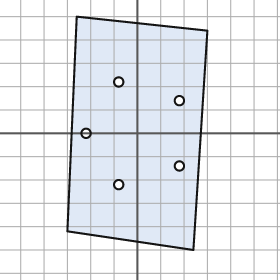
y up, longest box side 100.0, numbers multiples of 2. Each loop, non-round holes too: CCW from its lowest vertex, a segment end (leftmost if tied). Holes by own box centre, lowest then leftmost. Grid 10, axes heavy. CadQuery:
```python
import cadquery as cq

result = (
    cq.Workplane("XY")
    .moveTo(24.0, -50.0)
    .lineTo(30.0, 44.0)
    .lineTo(-26.0, 50.0)
    .lineTo(-30.0, -42.0)
    .close()
    .moveTo(-8.0, -22.0)
    .circle(2.0)
    .moveTo(18.0, -14.0)
    .circle(2.0)
    .moveTo(-22.0, 0.0)
    .circle(2.0)
    .moveTo(18.0, 14.0)
    .circle(2.0)
    .moveTo(-8.0, 22.0)
    .circle(2.0)
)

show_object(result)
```